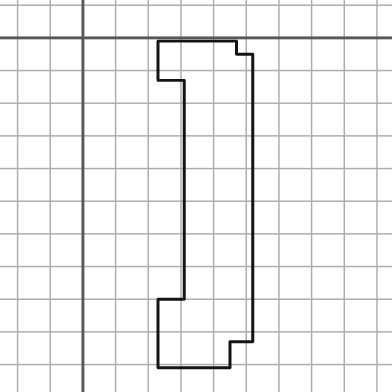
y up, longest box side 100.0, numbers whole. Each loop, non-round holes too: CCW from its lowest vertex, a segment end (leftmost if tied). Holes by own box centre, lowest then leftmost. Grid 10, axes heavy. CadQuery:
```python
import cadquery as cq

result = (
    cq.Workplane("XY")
    .moveTo(23.0, -101.0)
    .lineTo(45.0, -101.0)
    .lineTo(45.0, -93.0)
    .lineTo(52.0, -93.0)
    .lineTo(52.0, -5.0)
    .lineTo(47.0, -5.0)
    .lineTo(47.0, -1.0)
    .lineTo(23.0, -1.0)
    .lineTo(23.0, -13.0)
    .lineTo(31.0, -13.0)
    .lineTo(31.0, -80.0)
    .lineTo(23.0, -80.0)
    .close()
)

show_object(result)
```